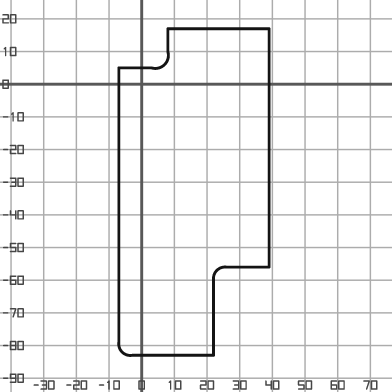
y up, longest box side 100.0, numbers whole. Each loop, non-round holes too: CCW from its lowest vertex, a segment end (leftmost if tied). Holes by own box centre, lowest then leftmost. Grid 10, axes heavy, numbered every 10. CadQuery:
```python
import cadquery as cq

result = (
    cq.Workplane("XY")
    .moveTo(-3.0, -83.0)
    .lineTo(22.0, -83.0)
    .lineTo(22.0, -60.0)
    .threePointArc((23.0, -57.0), (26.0, -56.0))
    .lineTo(39.0, -56.0)
    .lineTo(39.0, 17.0)
    .lineTo(8.0, 17.0)
    .lineTo(8.0, 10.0)
    .threePointArc((7.0, 6.0), (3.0, 5.0))
    .lineTo(-7.0, 5.0)
    .lineTo(-7.0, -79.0)
    .threePointArc((-6.0, -82.0), (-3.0, -83.0))
    .close()
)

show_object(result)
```